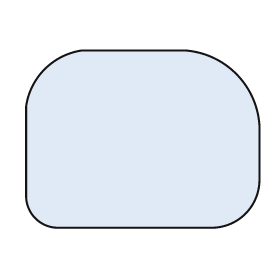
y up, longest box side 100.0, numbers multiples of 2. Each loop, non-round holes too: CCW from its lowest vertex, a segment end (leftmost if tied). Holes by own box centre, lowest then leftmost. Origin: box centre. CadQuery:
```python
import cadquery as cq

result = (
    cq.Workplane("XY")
    .moveTo(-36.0, -38.0)
    .lineTo(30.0, -38.0)
    .threePointArc((44.0, -32.0), (50.0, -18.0))
    .lineTo(50.0, 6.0)
    .threePointArc((40.0, 28.0), (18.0, 38.0))
    .lineTo(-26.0, 38.0)
    .threePointArc((-42.0, 30.0), (-50.0, 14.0))
    .lineTo(-50.0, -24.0)
    .threePointArc((-46.0, -34.0), (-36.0, -38.0))
    .close()
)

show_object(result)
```